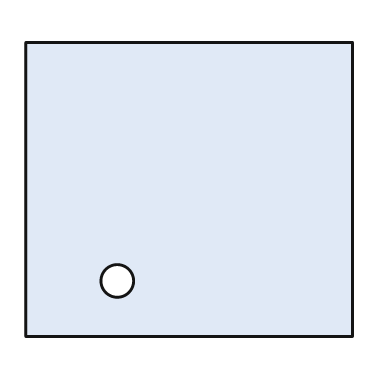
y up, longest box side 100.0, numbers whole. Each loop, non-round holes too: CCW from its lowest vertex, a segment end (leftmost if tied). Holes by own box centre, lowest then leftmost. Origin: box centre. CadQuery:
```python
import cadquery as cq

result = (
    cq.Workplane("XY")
    .moveTo(-50.0, -45.0)
    .lineTo(50.0, -45.0)
    .lineTo(50.0, 45.0)
    .lineTo(-50.0, 45.0)
    .close()
    .moveTo(-22.0, -28.0)
    .circle(5.0)
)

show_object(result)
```